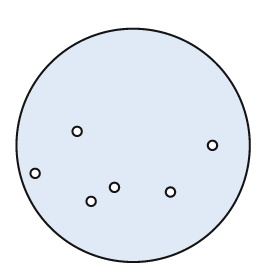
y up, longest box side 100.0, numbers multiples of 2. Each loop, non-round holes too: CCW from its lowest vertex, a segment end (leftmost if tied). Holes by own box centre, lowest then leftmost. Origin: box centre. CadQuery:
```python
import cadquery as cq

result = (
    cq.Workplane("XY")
    .moveTo(0.0, 0.0)
    .circle(50.0)
    .moveTo(-18.0, -24.0)
    .circle(2.0)
    .moveTo(16.0, -20.0)
    .circle(2.0)
    .moveTo(-8.0, -18.0)
    .circle(2.0)
    .moveTo(-42.0, -12.0)
    .circle(2.0)
    .moveTo(34.0, 0.0)
    .circle(2.0)
    .moveTo(-24.0, 6.0)
    .circle(2.0)
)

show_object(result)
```